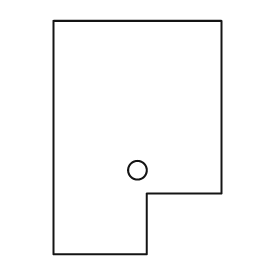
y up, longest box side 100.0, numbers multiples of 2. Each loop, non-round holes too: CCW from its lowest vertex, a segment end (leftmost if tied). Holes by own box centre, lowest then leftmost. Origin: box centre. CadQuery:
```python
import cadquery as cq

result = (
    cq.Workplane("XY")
    .moveTo(-36.0, -50.0)
    .lineTo(4.0, -50.0)
    .lineTo(4.0, -24.0)
    .lineTo(36.0, -24.0)
    .lineTo(36.0, 50.0)
    .lineTo(-36.0, 50.0)
    .close()
    .moveTo(0.0, -14.0)
    .circle(4.0)
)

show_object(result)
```